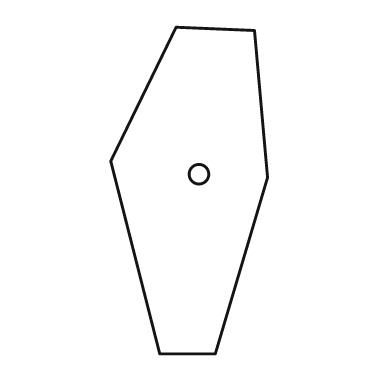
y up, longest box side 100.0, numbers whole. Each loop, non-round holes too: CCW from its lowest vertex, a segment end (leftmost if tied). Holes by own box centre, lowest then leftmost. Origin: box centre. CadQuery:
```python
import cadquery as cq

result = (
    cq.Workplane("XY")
    .moveTo(-9.0, -50.0)
    .lineTo(8.0, -50.0)
    .lineTo(24.0, 4.0)
    .lineTo(20.0, 49.0)
    .lineTo(-4.0, 50.0)
    .lineTo(-24.0, 9.0)
    .close()
    .moveTo(3.0, 5.0)
    .circle(3.0)
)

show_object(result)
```